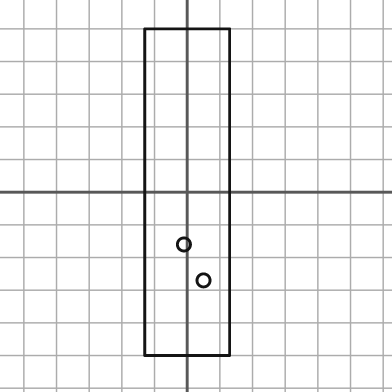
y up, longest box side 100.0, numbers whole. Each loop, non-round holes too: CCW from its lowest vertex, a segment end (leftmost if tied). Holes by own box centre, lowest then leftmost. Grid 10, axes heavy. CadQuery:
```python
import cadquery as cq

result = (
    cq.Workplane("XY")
    .moveTo(-13.0, -50.0)
    .lineTo(13.0, -50.0)
    .lineTo(13.0, 50.0)
    .lineTo(-13.0, 50.0)
    .close()
    .moveTo(5.0, -27.0)
    .circle(2.0)
    .moveTo(-1.0, -16.0)
    .circle(2.0)
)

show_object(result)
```